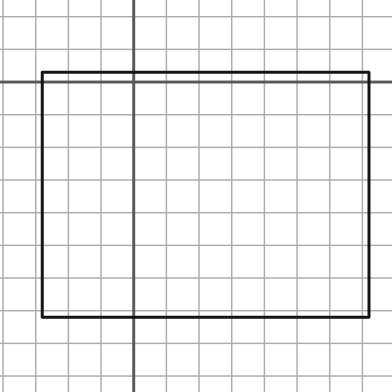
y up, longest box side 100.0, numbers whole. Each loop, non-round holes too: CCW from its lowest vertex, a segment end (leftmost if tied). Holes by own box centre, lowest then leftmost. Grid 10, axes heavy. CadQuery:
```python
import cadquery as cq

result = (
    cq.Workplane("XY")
    .moveTo(-28.0, -72.0)
    .lineTo(72.0, -72.0)
    .lineTo(72.0, 3.0)
    .lineTo(-28.0, 3.0)
    .close()
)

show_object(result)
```